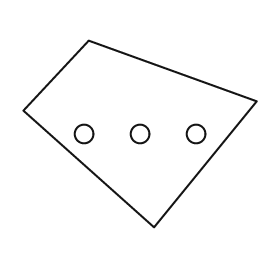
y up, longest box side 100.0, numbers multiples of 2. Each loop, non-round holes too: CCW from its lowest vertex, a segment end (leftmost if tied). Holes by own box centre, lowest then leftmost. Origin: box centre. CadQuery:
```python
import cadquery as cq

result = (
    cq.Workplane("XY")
    .moveTo(6.0, -40.0)
    .lineTo(50.0, 14.0)
    .lineTo(-22.0, 40.0)
    .lineTo(-50.0, 10.0)
    .close()
    .moveTo(-24.0, 0.0)
    .circle(4.0)
    .moveTo(0.0, 0.0)
    .circle(4.0)
    .moveTo(24.0, 0.0)
    .circle(4.0)
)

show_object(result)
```